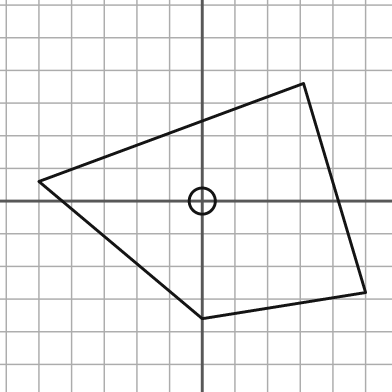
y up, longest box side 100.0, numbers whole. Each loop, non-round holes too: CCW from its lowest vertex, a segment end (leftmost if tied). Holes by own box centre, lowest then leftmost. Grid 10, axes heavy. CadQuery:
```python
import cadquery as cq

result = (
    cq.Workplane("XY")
    .moveTo(0.0, -36.0)
    .lineTo(50.0, -28.0)
    .lineTo(31.0, 36.0)
    .lineTo(-50.0, 6.0)
    .close()
    .moveTo(0.0, 0.0)
    .circle(4.0)
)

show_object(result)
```